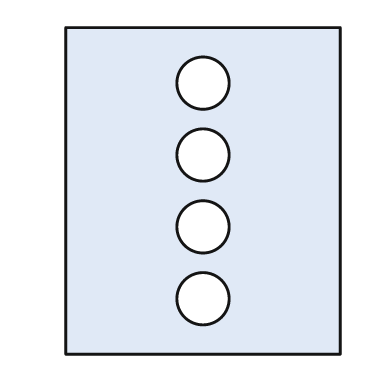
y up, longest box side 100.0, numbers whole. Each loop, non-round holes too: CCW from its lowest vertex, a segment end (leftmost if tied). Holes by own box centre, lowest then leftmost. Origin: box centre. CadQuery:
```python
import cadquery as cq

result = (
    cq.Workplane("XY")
    .moveTo(-42.0, -50.0)
    .lineTo(42.0, -50.0)
    .lineTo(42.0, 50.0)
    .lineTo(-42.0, 50.0)
    .close()
    .moveTo(0.0, -33.0)
    .circle(8.0)
    .moveTo(0.0, -11.0)
    .circle(8.0)
    .moveTo(0.0, 11.0)
    .circle(8.0)
    .moveTo(0.0, 33.0)
    .circle(8.0)
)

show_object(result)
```